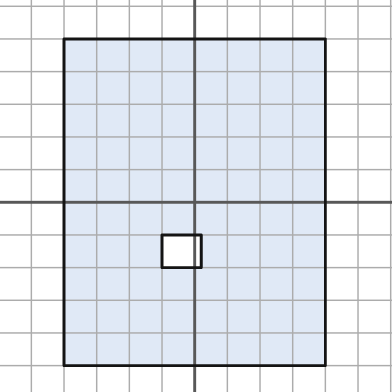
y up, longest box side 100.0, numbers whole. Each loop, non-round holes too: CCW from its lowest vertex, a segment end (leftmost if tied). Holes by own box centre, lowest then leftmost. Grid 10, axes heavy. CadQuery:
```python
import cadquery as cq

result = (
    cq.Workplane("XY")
    .moveTo(-40.0, -50.0)
    .lineTo(40.0, -50.0)
    .lineTo(40.0, 50.0)
    .lineTo(-40.0, 50.0)
    .close()
    .moveTo(-10.0, -20.0)
    .lineTo(2.0, -20.0)
    .lineTo(2.0, -10.0)
    .lineTo(-10.0, -10.0)
    .close()
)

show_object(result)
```